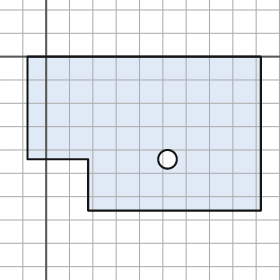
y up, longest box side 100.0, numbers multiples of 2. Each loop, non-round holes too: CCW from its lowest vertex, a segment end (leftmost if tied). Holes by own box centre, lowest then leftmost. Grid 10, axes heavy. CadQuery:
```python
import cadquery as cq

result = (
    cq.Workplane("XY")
    .moveTo(18.0, -66.0)
    .lineTo(92.0, -66.0)
    .lineTo(92.0, 0.0)
    .lineTo(-8.0, 0.0)
    .lineTo(-8.0, -44.0)
    .lineTo(18.0, -44.0)
    .close()
    .moveTo(52.0, -44.0)
    .circle(4.0)
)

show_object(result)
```